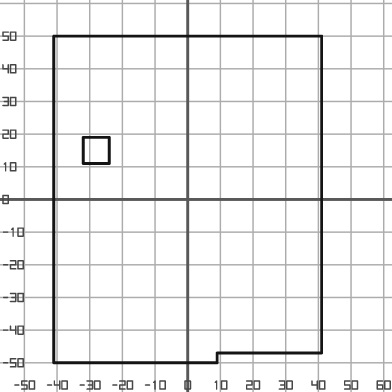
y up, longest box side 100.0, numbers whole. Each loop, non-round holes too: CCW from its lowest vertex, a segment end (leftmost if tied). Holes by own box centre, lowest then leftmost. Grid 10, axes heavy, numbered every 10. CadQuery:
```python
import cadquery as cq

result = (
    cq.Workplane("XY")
    .moveTo(-41.0, -50.0)
    .lineTo(9.0, -50.0)
    .lineTo(9.0, -47.0)
    .lineTo(41.0, -47.0)
    .lineTo(41.0, 50.0)
    .lineTo(-41.0, 50.0)
    .close()
    .moveTo(-32.0, 11.0)
    .lineTo(-24.0, 11.0)
    .lineTo(-24.0, 19.0)
    .lineTo(-32.0, 19.0)
    .close()
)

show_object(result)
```